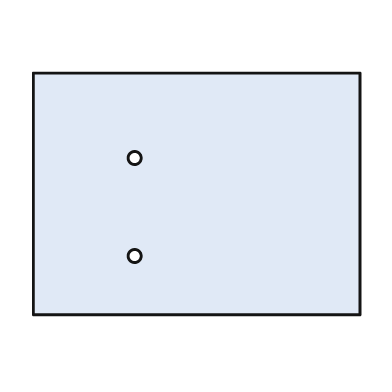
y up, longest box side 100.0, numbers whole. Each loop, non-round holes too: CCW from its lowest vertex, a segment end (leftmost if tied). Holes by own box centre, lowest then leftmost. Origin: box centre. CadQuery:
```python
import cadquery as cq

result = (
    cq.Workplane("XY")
    .moveTo(-50.0, -37.0)
    .lineTo(50.0, -37.0)
    .lineTo(50.0, 37.0)
    .lineTo(-50.0, 37.0)
    .close()
    .moveTo(-19.0, -19.0)
    .circle(2.0)
    .moveTo(-19.0, 11.0)
    .circle(2.0)
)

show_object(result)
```